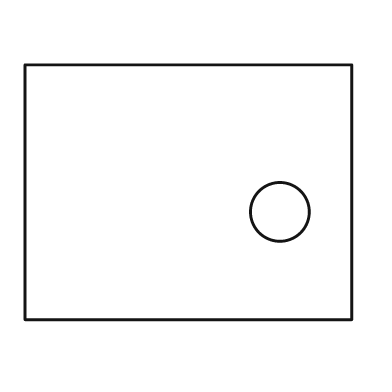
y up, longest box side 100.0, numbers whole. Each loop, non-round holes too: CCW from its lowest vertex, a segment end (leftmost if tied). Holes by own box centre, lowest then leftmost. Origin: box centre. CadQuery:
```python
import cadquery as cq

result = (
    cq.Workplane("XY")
    .moveTo(-50.0, -39.0)
    .lineTo(50.0, -39.0)
    .lineTo(50.0, 39.0)
    .lineTo(-50.0, 39.0)
    .close()
    .moveTo(28.0, -6.0)
    .circle(9.0)
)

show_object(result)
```